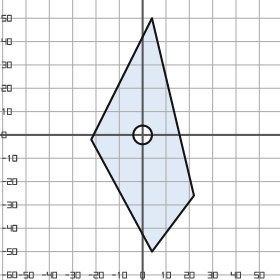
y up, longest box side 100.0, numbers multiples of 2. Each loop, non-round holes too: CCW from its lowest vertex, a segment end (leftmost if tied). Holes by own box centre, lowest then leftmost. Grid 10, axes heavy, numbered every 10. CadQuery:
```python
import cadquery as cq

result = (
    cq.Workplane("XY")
    .moveTo(4.0, -50.0)
    .lineTo(22.0, -26.0)
    .lineTo(4.0, 50.0)
    .lineTo(-22.0, -2.0)
    .close()
    .moveTo(0.0, 0.0)
    .circle(4.0)
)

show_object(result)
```